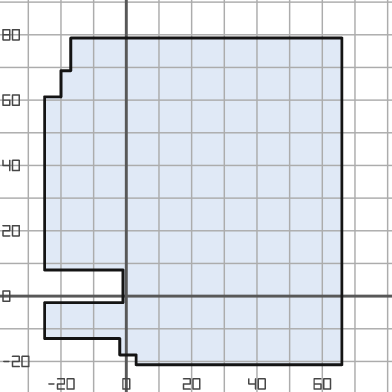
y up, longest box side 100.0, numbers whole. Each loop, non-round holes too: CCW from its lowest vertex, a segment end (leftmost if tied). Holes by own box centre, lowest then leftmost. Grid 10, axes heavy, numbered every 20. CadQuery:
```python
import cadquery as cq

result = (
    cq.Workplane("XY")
    .moveTo(3.0, -21.0)
    .lineTo(66.0, -21.0)
    .lineTo(66.0, 79.0)
    .lineTo(-17.0, 79.0)
    .lineTo(-17.0, 69.0)
    .lineTo(-20.0, 69.0)
    .lineTo(-20.0, 61.0)
    .lineTo(-25.0, 61.0)
    .lineTo(-25.0, 8.0)
    .lineTo(-1.0, 8.0)
    .lineTo(-1.0, -2.0)
    .lineTo(-25.0, -2.0)
    .lineTo(-25.0, -13.0)
    .lineTo(-2.0, -13.0)
    .lineTo(-2.0, -18.0)
    .lineTo(3.0, -18.0)
    .close()
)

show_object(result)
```